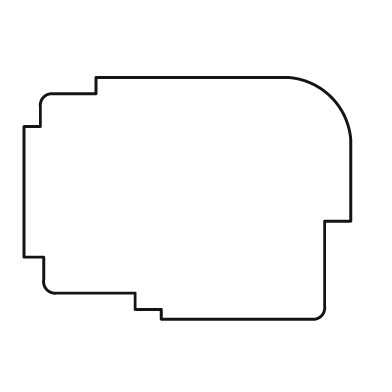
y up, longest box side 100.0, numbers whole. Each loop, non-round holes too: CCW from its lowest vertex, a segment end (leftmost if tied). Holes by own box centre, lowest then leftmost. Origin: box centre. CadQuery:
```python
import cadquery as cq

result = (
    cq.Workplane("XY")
    .moveTo(-8.0, -37.0)
    .lineTo(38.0, -37.0)
    .threePointArc((41.0, -36.0), (42.0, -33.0))
    .lineTo(42.0, -7.0)
    .lineTo(50.0, -7.0)
    .lineTo(50.0, 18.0)
    .threePointArc((44.0, 31.0), (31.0, 37.0))
    .lineTo(-28.0, 37.0)
    .lineTo(-28.0, 32.0)
    .lineTo(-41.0, 32.0)
    .threePointArc((-44.0, 31.0), (-45.0, 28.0))
    .lineTo(-45.0, 22.0)
    .lineTo(-50.0, 22.0)
    .lineTo(-50.0, -18.0)
    .lineTo(-44.0, -18.0)
    .lineTo(-44.0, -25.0)
    .threePointArc((-43.0, -28.0), (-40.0, -29.0))
    .lineTo(-16.0, -29.0)
    .lineTo(-16.0, -34.0)
    .lineTo(-8.0, -34.0)
    .close()
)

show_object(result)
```